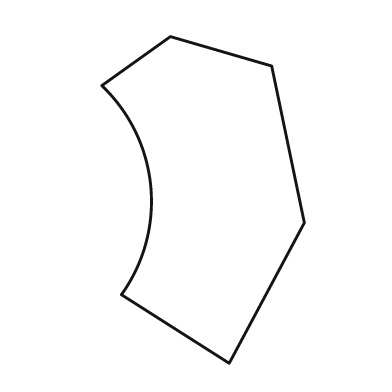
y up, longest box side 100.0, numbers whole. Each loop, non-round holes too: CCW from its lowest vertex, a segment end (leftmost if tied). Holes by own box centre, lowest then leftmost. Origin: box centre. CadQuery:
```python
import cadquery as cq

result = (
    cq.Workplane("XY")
    .moveTo(8.0, -50.0)
    .lineTo(31.0, -7.0)
    .lineTo(21.0, 41.0)
    .lineTo(-10.0, 50.0)
    .lineTo(-31.0, 35.0)
    .threePointArc((-16.0, 4.0), (-25.0, -29.0))
    .close()
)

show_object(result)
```